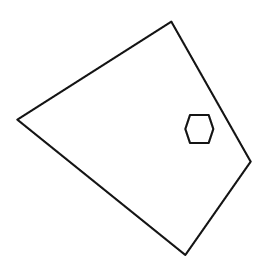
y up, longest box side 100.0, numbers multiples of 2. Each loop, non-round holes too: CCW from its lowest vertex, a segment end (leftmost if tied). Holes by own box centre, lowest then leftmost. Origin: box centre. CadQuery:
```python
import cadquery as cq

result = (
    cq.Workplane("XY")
    .moveTo(22.0, -50.0)
    .lineTo(50.0, -10.0)
    .lineTo(16.0, 50.0)
    .lineTo(-50.0, 8.0)
    .close()
    .moveTo(24.0, -2.0)
    .lineTo(32.0, -2.0)
    .lineTo(34.0, 4.0)
    .lineTo(32.0, 10.0)
    .lineTo(24.0, 10.0)
    .lineTo(22.0, 4.0)
    .close()
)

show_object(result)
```